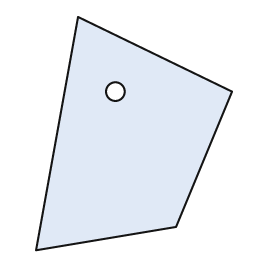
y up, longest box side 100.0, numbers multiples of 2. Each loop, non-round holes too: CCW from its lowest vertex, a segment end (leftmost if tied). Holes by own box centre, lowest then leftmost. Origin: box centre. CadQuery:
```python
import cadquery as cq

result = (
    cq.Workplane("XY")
    .moveTo(-42.0, -50.0)
    .lineTo(18.0, -40.0)
    .lineTo(42.0, 18.0)
    .lineTo(-24.0, 50.0)
    .close()
    .moveTo(-8.0, 18.0)
    .circle(4.0)
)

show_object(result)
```